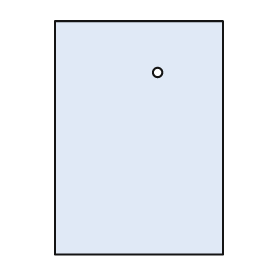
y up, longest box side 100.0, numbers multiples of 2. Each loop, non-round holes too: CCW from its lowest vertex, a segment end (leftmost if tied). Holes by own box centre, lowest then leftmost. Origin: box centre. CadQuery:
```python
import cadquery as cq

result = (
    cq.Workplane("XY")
    .moveTo(-36.0, -50.0)
    .lineTo(36.0, -50.0)
    .lineTo(36.0, 50.0)
    .lineTo(-36.0, 50.0)
    .close()
    .moveTo(8.0, 28.0)
    .circle(2.0)
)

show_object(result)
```